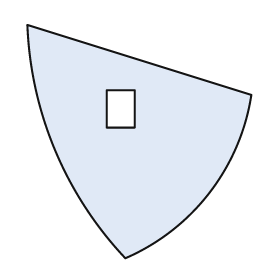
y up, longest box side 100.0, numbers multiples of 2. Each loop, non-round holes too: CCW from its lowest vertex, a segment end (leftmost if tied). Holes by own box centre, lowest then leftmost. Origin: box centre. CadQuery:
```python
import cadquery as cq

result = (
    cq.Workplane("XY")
    .moveTo(-6.0, -50.0)
    .threePointArc((30.0, -22.0), (48.0, 20.0))
    .lineTo(-48.0, 50.0)
    .threePointArc((-36.0, -4.0), (-6.0, -50.0))
    .close()
    .moveTo(-14.0, 6.0)
    .lineTo(-2.0, 6.0)
    .lineTo(-2.0, 22.0)
    .lineTo(-14.0, 22.0)
    .close()
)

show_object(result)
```